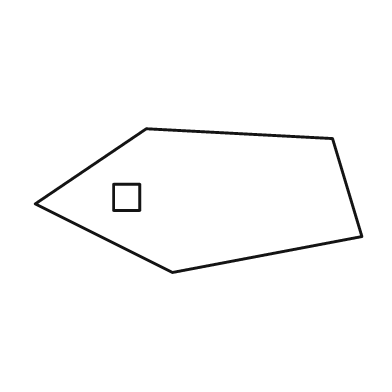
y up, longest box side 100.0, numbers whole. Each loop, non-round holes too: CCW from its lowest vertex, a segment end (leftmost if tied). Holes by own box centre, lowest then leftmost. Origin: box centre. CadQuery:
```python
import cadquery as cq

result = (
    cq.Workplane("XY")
    .moveTo(-8.0, -22.0)
    .lineTo(50.0, -11.0)
    .lineTo(41.0, 19.0)
    .lineTo(-16.0, 22.0)
    .lineTo(-50.0, -1.0)
    .close()
    .moveTo(-26.0, -3.0)
    .lineTo(-18.0, -3.0)
    .lineTo(-18.0, 5.0)
    .lineTo(-26.0, 5.0)
    .close()
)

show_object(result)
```